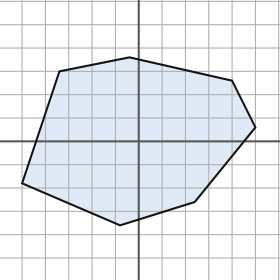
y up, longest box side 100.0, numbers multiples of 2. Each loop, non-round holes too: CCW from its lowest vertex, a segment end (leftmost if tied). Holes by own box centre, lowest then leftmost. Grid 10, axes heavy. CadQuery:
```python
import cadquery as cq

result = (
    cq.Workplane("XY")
    .moveTo(-8.0, -36.0)
    .lineTo(24.0, -26.0)
    .lineTo(50.0, 6.0)
    .lineTo(40.0, 26.0)
    .lineTo(-4.0, 36.0)
    .lineTo(-34.0, 30.0)
    .lineTo(-50.0, -18.0)
    .close()
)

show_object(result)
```